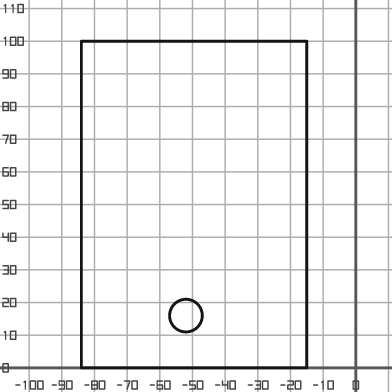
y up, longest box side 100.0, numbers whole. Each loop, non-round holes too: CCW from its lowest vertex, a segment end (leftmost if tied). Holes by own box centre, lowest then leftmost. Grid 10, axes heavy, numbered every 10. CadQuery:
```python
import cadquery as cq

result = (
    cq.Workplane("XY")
    .moveTo(-84.0, 0.0)
    .lineTo(-15.0, 0.0)
    .lineTo(-15.0, 100.0)
    .lineTo(-84.0, 100.0)
    .close()
    .moveTo(-52.0, 16.0)
    .circle(5.0)
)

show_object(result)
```